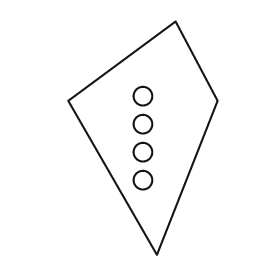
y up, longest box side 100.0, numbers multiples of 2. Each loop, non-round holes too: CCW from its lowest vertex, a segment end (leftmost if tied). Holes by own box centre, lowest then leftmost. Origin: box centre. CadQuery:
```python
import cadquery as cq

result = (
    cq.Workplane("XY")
    .moveTo(6.0, -50.0)
    .lineTo(32.0, 16.0)
    .lineTo(14.0, 50.0)
    .lineTo(-32.0, 16.0)
    .close()
    .moveTo(0.0, -18.0)
    .circle(4.0)
    .moveTo(0.0, -6.0)
    .circle(4.0)
    .moveTo(0.0, 6.0)
    .circle(4.0)
    .moveTo(0.0, 18.0)
    .circle(4.0)
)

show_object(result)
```